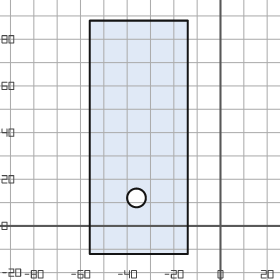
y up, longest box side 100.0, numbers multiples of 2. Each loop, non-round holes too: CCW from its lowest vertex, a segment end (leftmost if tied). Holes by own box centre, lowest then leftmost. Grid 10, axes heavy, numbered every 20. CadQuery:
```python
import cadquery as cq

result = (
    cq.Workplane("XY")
    .moveTo(-56.0, -12.0)
    .lineTo(-14.0, -12.0)
    .lineTo(-14.0, 88.0)
    .lineTo(-56.0, 88.0)
    .close()
    .moveTo(-36.0, 12.0)
    .circle(4.0)
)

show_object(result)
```